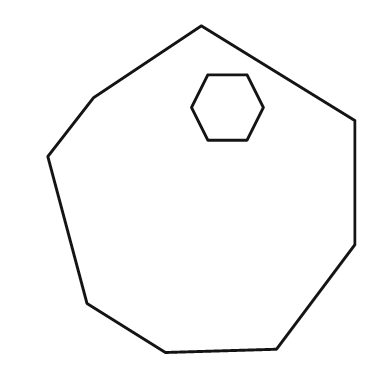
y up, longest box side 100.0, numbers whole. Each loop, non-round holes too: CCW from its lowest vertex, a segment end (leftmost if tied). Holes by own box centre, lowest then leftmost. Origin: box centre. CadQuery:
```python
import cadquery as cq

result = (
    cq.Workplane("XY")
    .moveTo(-11.0, -50.0)
    .lineTo(23.0, -49.0)
    .lineTo(47.0, -17.0)
    .lineTo(47.0, 21.0)
    .lineTo(0.0, 50.0)
    .lineTo(-33.0, 28.0)
    .lineTo(-47.0, 10.0)
    .lineTo(-35.0, -35.0)
    .close()
    .moveTo(2.0, 15.0)
    .lineTo(14.0, 15.0)
    .lineTo(19.0, 25.0)
    .lineTo(14.0, 35.0)
    .lineTo(2.0, 35.0)
    .lineTo(-3.0, 25.0)
    .close()
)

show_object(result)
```